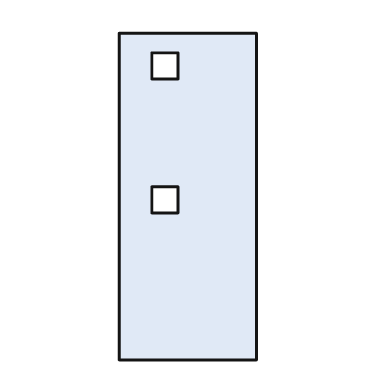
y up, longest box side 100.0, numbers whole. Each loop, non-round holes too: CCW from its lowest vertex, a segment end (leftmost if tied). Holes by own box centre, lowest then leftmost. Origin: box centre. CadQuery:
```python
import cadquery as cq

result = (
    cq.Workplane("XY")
    .moveTo(-21.0, -50.0)
    .lineTo(21.0, -50.0)
    .lineTo(21.0, 50.0)
    .lineTo(-21.0, 50.0)
    .close()
    .moveTo(-11.0, -5.0)
    .lineTo(-3.0, -5.0)
    .lineTo(-3.0, 3.0)
    .lineTo(-11.0, 3.0)
    .close()
    .moveTo(-11.0, 36.0)
    .lineTo(-3.0, 36.0)
    .lineTo(-3.0, 44.0)
    .lineTo(-11.0, 44.0)
    .close()
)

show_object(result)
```